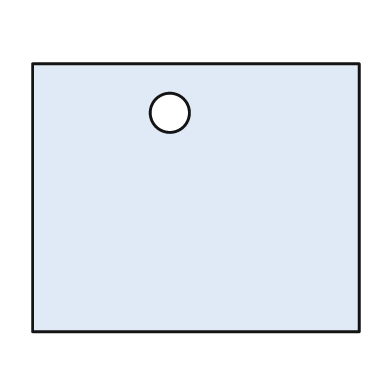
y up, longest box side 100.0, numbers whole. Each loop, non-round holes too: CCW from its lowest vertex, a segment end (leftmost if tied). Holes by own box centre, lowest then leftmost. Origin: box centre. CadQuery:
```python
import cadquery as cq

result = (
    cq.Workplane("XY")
    .moveTo(-50.0, -41.0)
    .lineTo(50.0, -41.0)
    .lineTo(50.0, 41.0)
    .lineTo(-50.0, 41.0)
    .close()
    .moveTo(-8.0, 26.0)
    .circle(6.0)
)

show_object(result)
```